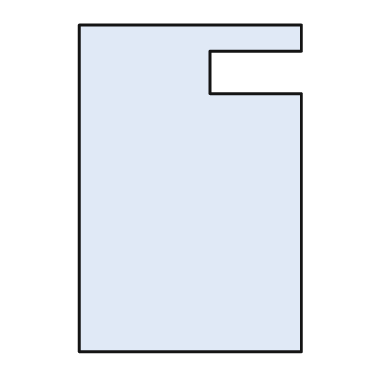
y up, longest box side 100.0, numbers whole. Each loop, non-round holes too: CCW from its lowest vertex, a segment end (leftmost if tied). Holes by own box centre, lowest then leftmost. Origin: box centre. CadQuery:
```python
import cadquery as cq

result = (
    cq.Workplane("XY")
    .moveTo(-34.0, -50.0)
    .lineTo(34.0, -50.0)
    .lineTo(34.0, 29.0)
    .lineTo(6.0, 29.0)
    .lineTo(6.0, 42.0)
    .lineTo(34.0, 42.0)
    .lineTo(34.0, 50.0)
    .lineTo(-34.0, 50.0)
    .close()
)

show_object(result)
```